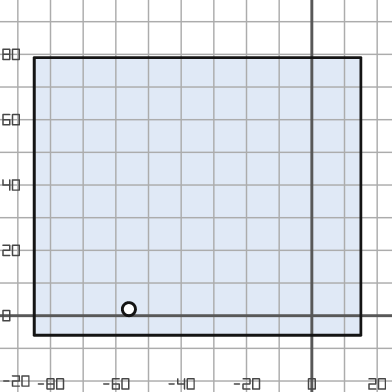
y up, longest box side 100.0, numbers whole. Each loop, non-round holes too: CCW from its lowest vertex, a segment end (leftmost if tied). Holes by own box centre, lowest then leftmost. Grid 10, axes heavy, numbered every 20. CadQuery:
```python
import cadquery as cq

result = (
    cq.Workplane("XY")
    .moveTo(-85.0, -6.0)
    .lineTo(15.0, -6.0)
    .lineTo(15.0, 79.0)
    .lineTo(-85.0, 79.0)
    .close()
    .moveTo(-56.0, 2.0)
    .circle(2.0)
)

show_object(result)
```